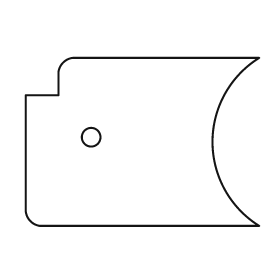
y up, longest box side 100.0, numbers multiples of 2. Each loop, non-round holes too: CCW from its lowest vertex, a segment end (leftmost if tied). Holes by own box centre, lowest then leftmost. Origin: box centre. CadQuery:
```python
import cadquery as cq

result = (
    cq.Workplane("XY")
    .moveTo(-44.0, -36.0)
    .lineTo(50.0, -36.0)
    .threePointArc((30.0, 0.0), (50.0, 36.0))
    .lineTo(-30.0, 36.0)
    .threePointArc((-34.0, 34.0), (-36.0, 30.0))
    .lineTo(-36.0, 20.0)
    .lineTo(-50.0, 20.0)
    .lineTo(-50.0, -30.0)
    .threePointArc((-48.0, -34.0), (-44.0, -36.0))
    .close()
    .moveTo(-22.0, 2.0)
    .circle(4.0)
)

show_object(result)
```